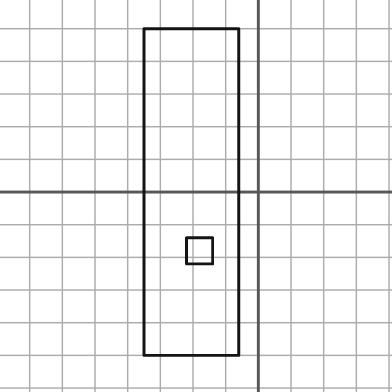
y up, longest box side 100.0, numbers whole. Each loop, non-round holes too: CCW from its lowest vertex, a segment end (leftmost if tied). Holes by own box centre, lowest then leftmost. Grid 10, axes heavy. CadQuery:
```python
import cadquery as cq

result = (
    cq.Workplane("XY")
    .moveTo(-35.0, -50.0)
    .lineTo(-6.0, -50.0)
    .lineTo(-6.0, 50.0)
    .lineTo(-35.0, 50.0)
    .close()
    .moveTo(-22.0, -22.0)
    .lineTo(-14.0, -22.0)
    .lineTo(-14.0, -14.0)
    .lineTo(-22.0, -14.0)
    .close()
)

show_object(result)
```